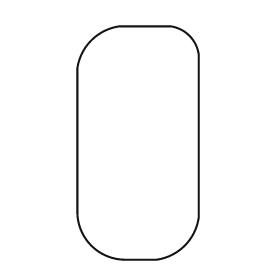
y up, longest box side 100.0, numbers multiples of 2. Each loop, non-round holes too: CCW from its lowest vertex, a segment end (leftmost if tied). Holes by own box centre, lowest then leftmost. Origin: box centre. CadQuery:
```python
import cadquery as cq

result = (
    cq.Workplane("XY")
    .moveTo(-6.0, -50.0)
    .lineTo(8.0, -50.0)
    .threePointArc((20.0, -44.0), (26.0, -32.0))
    .lineTo(26.0, 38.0)
    .threePointArc((22.0, 46.0), (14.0, 50.0))
    .lineTo(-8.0, 50.0)
    .threePointArc((-20.0, 44.0), (-26.0, 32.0))
    .lineTo(-26.0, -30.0)
    .threePointArc((-20.0, -44.0), (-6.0, -50.0))
    .close()
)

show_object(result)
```